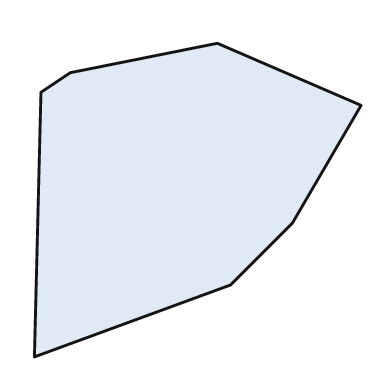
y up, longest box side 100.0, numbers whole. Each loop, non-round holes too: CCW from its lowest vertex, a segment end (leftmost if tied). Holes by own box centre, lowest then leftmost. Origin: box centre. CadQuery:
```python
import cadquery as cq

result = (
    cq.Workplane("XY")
    .moveTo(-50.0, -48.0)
    .lineTo(10.0, -26.0)
    .lineTo(29.0, -7.0)
    .lineTo(50.0, 29.0)
    .lineTo(6.0, 48.0)
    .lineTo(-39.0, 39.0)
    .lineTo(-48.0, 33.0)
    .close()
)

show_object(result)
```